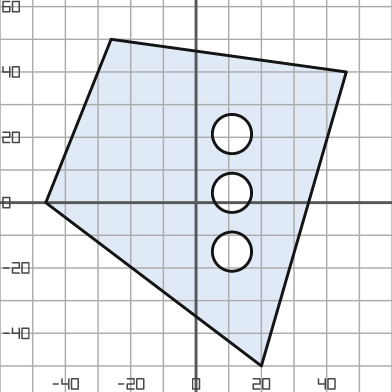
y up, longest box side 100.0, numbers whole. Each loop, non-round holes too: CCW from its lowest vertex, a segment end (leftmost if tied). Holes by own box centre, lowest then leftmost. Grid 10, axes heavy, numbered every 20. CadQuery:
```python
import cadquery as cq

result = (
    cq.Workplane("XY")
    .moveTo(20.0, -50.0)
    .lineTo(46.0, 40.0)
    .lineTo(-26.0, 50.0)
    .lineTo(-46.0, 0.0)
    .close()
    .moveTo(11.0, -15.0)
    .circle(6.0)
    .moveTo(11.0, 3.0)
    .circle(6.0)
    .moveTo(11.0, 21.0)
    .circle(6.0)
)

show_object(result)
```